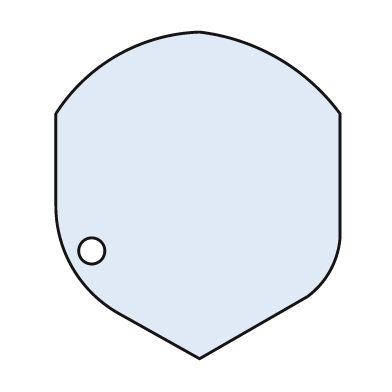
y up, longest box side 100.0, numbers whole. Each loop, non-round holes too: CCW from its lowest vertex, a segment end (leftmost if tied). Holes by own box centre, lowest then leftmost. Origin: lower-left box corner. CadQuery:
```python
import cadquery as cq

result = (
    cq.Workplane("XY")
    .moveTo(44.0, 0.0)
    .lineTo(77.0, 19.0)
    .threePointArc((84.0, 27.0), (87.0, 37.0))
    .lineTo(87.0, 75.0)
    .threePointArc((68.0, 92.0), (44.0, 100.0))
    .threePointArc((19.0, 93.0), (0.0, 75.0))
    .lineTo(0.0, 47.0)
    .threePointArc((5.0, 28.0), (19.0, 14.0))
    .close()
    .moveTo(11.0, 33.0)
    .circle(4.0)
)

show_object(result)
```